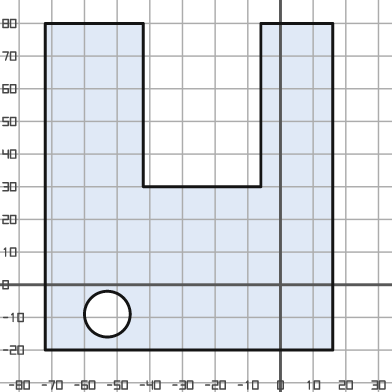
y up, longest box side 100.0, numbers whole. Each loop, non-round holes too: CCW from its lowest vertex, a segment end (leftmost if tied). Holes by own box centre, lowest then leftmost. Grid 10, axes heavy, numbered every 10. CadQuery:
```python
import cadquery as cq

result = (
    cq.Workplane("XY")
    .moveTo(-72.0, -20.0)
    .lineTo(16.0, -20.0)
    .lineTo(16.0, 80.0)
    .lineTo(-6.0, 80.0)
    .lineTo(-6.0, 30.0)
    .lineTo(-42.0, 30.0)
    .lineTo(-42.0, 80.0)
    .lineTo(-72.0, 80.0)
    .close()
    .moveTo(-53.0, -9.0)
    .circle(7.0)
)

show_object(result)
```